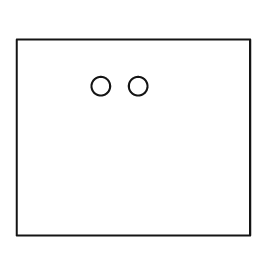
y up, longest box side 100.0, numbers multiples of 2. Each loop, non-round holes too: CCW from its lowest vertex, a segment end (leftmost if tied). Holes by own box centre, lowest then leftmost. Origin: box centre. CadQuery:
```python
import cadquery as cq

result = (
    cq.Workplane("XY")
    .moveTo(-50.0, -42.0)
    .lineTo(50.0, -42.0)
    .lineTo(50.0, 42.0)
    .lineTo(-50.0, 42.0)
    .close()
    .moveTo(-14.0, 22.0)
    .circle(4.0)
    .moveTo(2.0, 22.0)
    .circle(4.0)
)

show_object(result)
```